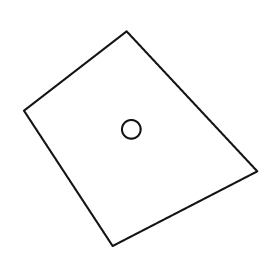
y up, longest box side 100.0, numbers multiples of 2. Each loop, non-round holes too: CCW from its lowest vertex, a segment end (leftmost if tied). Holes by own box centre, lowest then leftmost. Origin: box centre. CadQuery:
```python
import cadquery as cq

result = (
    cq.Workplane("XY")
    .moveTo(-12.0, -46.0)
    .lineTo(50.0, -14.0)
    .lineTo(-6.0, 46.0)
    .lineTo(-50.0, 12.0)
    .close()
    .moveTo(-4.0, 4.0)
    .circle(4.0)
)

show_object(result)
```